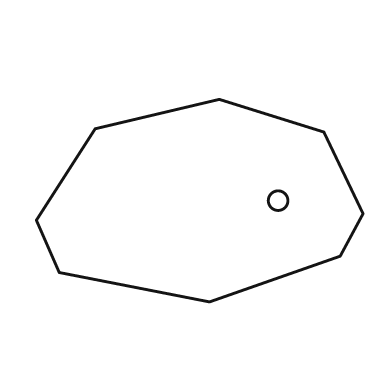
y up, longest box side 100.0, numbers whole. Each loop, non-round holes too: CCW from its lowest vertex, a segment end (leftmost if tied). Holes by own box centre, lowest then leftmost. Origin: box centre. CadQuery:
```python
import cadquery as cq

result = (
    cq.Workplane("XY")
    .moveTo(3.0, -31.0)
    .lineTo(43.0, -17.0)
    .lineTo(50.0, -4.0)
    .lineTo(38.0, 21.0)
    .lineTo(6.0, 31.0)
    .lineTo(-32.0, 22.0)
    .lineTo(-50.0, -6.0)
    .lineTo(-43.0, -22.0)
    .close()
    .moveTo(24.0, 0.0)
    .circle(3.0)
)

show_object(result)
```